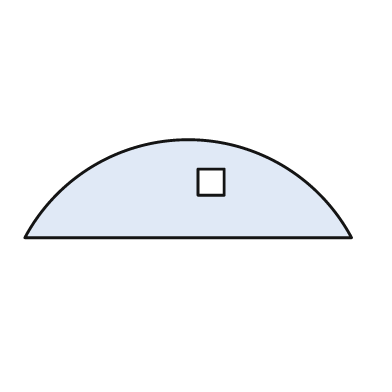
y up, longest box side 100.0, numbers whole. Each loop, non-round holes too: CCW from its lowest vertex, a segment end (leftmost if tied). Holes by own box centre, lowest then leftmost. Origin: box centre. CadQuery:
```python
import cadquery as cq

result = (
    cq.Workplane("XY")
    .moveTo(-50.0, -15.0)
    .lineTo(50.0, -15.0)
    .threePointArc((0.0, 15.0), (-50.0, -15.0))
    .close()
    .moveTo(3.0, -2.0)
    .lineTo(11.0, -2.0)
    .lineTo(11.0, 6.0)
    .lineTo(3.0, 6.0)
    .close()
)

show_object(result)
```